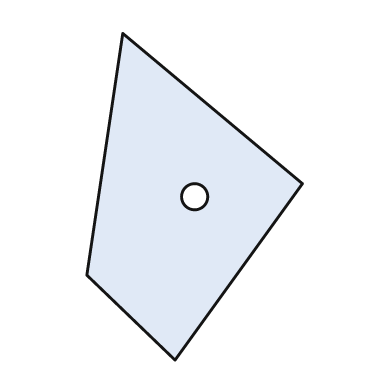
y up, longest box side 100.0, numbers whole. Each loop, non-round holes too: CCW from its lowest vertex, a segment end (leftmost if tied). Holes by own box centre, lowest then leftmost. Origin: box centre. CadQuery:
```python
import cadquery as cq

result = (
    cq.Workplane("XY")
    .moveTo(-6.0, -50.0)
    .lineTo(33.0, 4.0)
    .lineTo(-22.0, 50.0)
    .lineTo(-33.0, -24.0)
    .close()
    .moveTo(0.0, 0.0)
    .circle(4.0)
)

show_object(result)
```